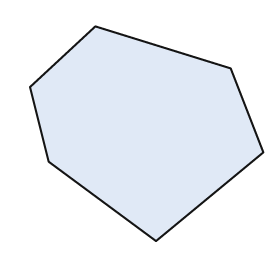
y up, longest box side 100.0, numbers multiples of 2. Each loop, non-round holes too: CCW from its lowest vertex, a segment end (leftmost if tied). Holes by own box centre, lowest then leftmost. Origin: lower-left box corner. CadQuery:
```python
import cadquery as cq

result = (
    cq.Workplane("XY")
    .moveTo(54.0, 0.0)
    .lineTo(100.0, 38.0)
    .lineTo(86.0, 74.0)
    .lineTo(28.0, 92.0)
    .lineTo(0.0, 66.0)
    .lineTo(8.0, 34.0)
    .close()
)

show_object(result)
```